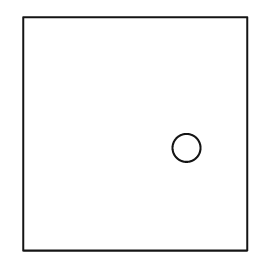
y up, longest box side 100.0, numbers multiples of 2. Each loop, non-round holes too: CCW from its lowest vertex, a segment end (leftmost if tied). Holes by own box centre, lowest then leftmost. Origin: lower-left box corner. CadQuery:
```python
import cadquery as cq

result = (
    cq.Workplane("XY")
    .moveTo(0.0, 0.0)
    .lineTo(96.0, 0.0)
    .lineTo(96.0, 100.0)
    .lineTo(0.0, 100.0)
    .close()
    .moveTo(70.0, 44.0)
    .circle(6.0)
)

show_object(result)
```